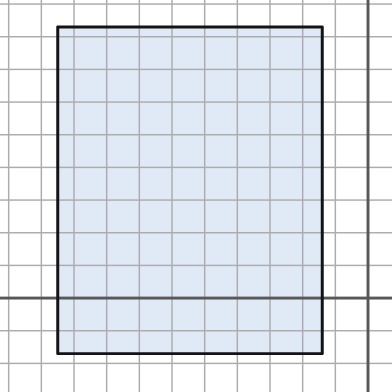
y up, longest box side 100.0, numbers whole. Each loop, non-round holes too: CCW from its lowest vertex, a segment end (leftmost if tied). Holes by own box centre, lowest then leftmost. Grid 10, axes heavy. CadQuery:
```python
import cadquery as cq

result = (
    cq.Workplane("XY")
    .moveTo(-95.0, -17.0)
    .lineTo(-14.0, -17.0)
    .lineTo(-14.0, 83.0)
    .lineTo(-95.0, 83.0)
    .close()
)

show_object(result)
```